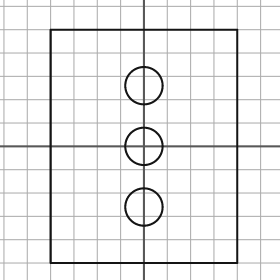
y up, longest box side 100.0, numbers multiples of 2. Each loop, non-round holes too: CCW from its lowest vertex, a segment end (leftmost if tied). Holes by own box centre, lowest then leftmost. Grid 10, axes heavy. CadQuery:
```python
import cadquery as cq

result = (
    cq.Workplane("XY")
    .moveTo(-40.0, -50.0)
    .lineTo(40.0, -50.0)
    .lineTo(40.0, 50.0)
    .lineTo(-40.0, 50.0)
    .close()
    .moveTo(0.0, -26.0)
    .circle(8.0)
    .moveTo(0.0, 0.0)
    .circle(8.0)
    .moveTo(0.0, 26.0)
    .circle(8.0)
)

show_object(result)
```